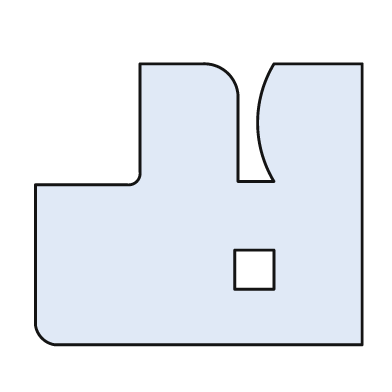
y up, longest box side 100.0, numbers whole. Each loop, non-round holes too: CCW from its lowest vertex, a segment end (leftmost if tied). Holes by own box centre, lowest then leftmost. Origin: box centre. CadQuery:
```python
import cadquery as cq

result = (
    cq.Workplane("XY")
    .moveTo(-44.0, -43.0)
    .lineTo(50.0, -43.0)
    .lineTo(50.0, 43.0)
    .lineTo(23.0, 43.0)
    .threePointArc((18.0, 25.0), (23.0, 7.0))
    .lineTo(12.0, 7.0)
    .lineTo(12.0, 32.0)
    .threePointArc((9.0, 40.0), (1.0, 43.0))
    .lineTo(-18.0, 43.0)
    .lineTo(-18.0, 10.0)
    .threePointArc((-19.0, 7.0), (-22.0, 6.0))
    .lineTo(-50.0, 6.0)
    .lineTo(-50.0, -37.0)
    .threePointArc((-48.0, -41.0), (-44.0, -43.0))
    .close()
    .moveTo(11.0, -26.0)
    .lineTo(23.0, -26.0)
    .lineTo(23.0, -14.0)
    .lineTo(11.0, -14.0)
    .close()
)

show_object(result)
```